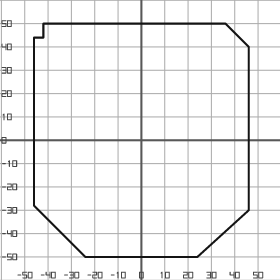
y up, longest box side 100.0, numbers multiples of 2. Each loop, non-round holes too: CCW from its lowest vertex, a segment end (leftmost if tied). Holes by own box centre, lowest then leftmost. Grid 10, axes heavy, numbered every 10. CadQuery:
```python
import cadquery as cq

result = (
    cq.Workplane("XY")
    .moveTo(-24.0, -50.0)
    .lineTo(24.0, -50.0)
    .lineTo(46.0, -30.0)
    .lineTo(46.0, 40.0)
    .lineTo(36.0, 50.0)
    .lineTo(-42.0, 50.0)
    .lineTo(-42.0, 44.0)
    .lineTo(-46.0, 44.0)
    .lineTo(-46.0, -28.0)
    .close()
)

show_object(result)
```